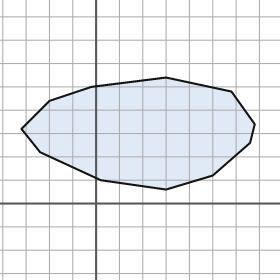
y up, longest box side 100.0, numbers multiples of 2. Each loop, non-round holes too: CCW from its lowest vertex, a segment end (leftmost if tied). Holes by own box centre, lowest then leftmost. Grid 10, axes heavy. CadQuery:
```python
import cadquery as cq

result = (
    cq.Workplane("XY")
    .moveTo(30.0, 6.0)
    .lineTo(50.0, 12.0)
    .lineTo(66.0, 26.0)
    .lineTo(68.0, 34.0)
    .lineTo(58.0, 48.0)
    .lineTo(30.0, 54.0)
    .lineTo(-2.0, 50.0)
    .lineTo(-20.0, 44.0)
    .lineTo(-32.0, 32.0)
    .lineTo(-24.0, 22.0)
    .lineTo(2.0, 10.0)
    .close()
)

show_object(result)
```